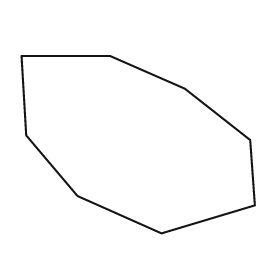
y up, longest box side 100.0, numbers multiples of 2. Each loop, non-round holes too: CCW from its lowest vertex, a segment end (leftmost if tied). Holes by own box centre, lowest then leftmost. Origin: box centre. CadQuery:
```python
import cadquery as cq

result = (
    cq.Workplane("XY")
    .moveTo(10.0, -38.0)
    .lineTo(50.0, -26.0)
    .lineTo(48.0, 2.0)
    .lineTo(20.0, 24.0)
    .lineTo(-12.0, 38.0)
    .lineTo(-50.0, 38.0)
    .lineTo(-48.0, 4.0)
    .lineTo(-26.0, -22.0)
    .close()
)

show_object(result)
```